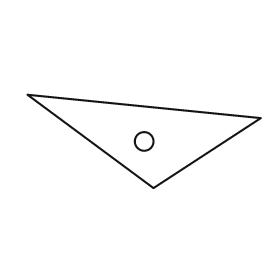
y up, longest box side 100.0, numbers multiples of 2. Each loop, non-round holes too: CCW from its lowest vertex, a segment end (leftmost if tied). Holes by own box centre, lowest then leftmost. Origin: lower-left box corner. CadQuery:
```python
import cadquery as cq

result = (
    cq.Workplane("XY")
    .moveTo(54.0, 0.0)
    .lineTo(100.0, 30.0)
    .lineTo(0.0, 40.0)
    .close()
    .moveTo(50.0, 20.0)
    .circle(4.0)
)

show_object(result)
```